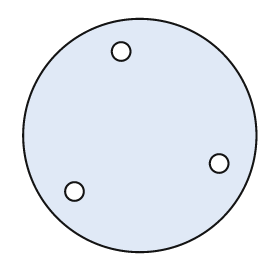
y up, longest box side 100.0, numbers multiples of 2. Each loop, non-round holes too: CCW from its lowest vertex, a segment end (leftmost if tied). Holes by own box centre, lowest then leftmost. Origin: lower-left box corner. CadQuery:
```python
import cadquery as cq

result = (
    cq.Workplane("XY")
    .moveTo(50.0, 50.0)
    .circle(50.0)
    .moveTo(22.0, 26.0)
    .circle(4.0)
    .moveTo(84.0, 38.0)
    .circle(4.0)
    .moveTo(42.0, 86.0)
    .circle(4.0)
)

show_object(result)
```